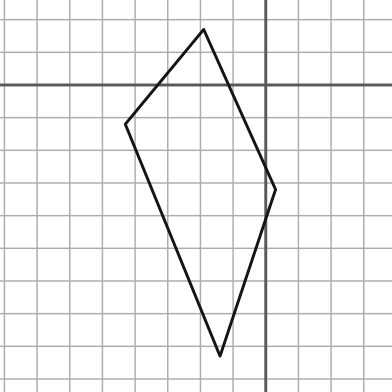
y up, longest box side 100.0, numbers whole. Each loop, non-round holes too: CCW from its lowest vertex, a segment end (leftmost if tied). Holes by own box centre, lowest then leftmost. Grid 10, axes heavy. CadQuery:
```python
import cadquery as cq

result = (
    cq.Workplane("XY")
    .moveTo(-14.0, -83.0)
    .lineTo(3.0, -32.0)
    .lineTo(-19.0, 17.0)
    .lineTo(-43.0, -12.0)
    .close()
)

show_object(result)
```